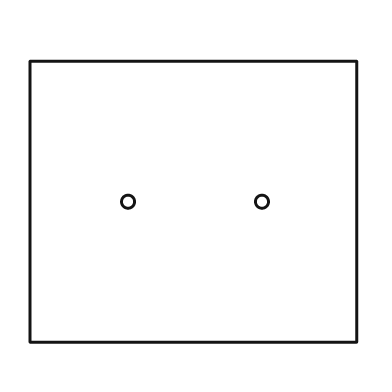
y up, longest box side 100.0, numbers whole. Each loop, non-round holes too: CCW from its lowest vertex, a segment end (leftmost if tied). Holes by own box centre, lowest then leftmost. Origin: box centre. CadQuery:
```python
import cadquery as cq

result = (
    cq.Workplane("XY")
    .moveTo(-50.0, -43.0)
    .lineTo(50.0, -43.0)
    .lineTo(50.0, 43.0)
    .lineTo(-50.0, 43.0)
    .close()
    .moveTo(-20.0, 0.0)
    .circle(2.0)
    .moveTo(21.0, 0.0)
    .circle(2.0)
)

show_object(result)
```